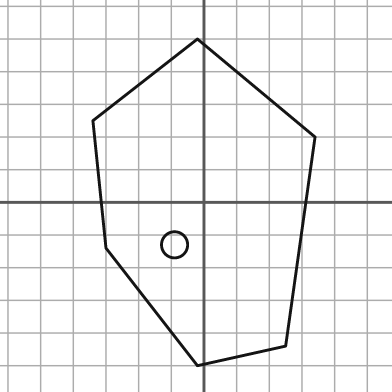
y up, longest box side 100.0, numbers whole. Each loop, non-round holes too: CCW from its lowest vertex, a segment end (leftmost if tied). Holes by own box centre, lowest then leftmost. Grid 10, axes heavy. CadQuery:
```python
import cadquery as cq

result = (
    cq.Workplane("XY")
    .moveTo(-2.0, -50.0)
    .lineTo(25.0, -44.0)
    .lineTo(34.0, 20.0)
    .lineTo(-2.0, 50.0)
    .lineTo(-34.0, 25.0)
    .lineTo(-30.0, -14.0)
    .close()
    .moveTo(-9.0, -13.0)
    .circle(4.0)
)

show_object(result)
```